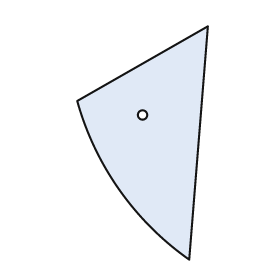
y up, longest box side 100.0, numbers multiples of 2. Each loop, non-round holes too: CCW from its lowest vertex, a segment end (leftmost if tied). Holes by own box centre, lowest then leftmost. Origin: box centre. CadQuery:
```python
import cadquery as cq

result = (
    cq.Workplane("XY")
    .moveTo(20.0, -50.0)
    .lineTo(28.0, 50.0)
    .lineTo(-28.0, 18.0)
    .threePointArc((-10.0, -20.0), (20.0, -50.0))
    .close()
    .moveTo(0.0, 12.0)
    .circle(2.0)
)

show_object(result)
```